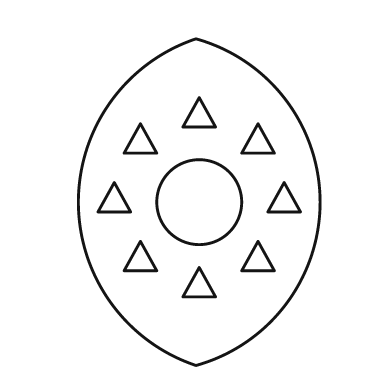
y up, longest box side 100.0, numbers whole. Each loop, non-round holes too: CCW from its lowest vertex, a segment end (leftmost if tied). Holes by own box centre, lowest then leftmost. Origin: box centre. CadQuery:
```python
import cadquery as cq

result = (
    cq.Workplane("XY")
    .moveTo(-1.0, -50.0)
    .threePointArc((37.0, 0.0), (-1.0, 50.0))
    .threePointArc((-37.0, 0.0), (-1.0, -50.0))
    .close()
    .moveTo(-5.0, -29.0)
    .lineTo(5.0, -29.0)
    .lineTo(0.0, -20.0)
    .close()
    .moveTo(-23.0, -21.0)
    .lineTo(-13.0, -21.0)
    .lineTo(-18.0, -12.0)
    .close()
    .moveTo(13.0, -21.0)
    .lineTo(23.0, -21.0)
    .lineTo(18.0, -12.0)
    .close()
    .moveTo(0.0, 0.0)
    .circle(13.0)
    .moveTo(-31.0, -3.0)
    .lineTo(-21.0, -3.0)
    .lineTo(-26.0, 6.0)
    .close()
    .moveTo(21.0, -3.0)
    .lineTo(31.0, -3.0)
    .lineTo(26.0, 6.0)
    .close()
    .moveTo(-23.0, 15.0)
    .lineTo(-13.0, 15.0)
    .lineTo(-18.0, 24.0)
    .close()
    .moveTo(13.0, 15.0)
    .lineTo(23.0, 15.0)
    .lineTo(18.0, 24.0)
    .close()
    .moveTo(-5.0, 23.0)
    .lineTo(5.0, 23.0)
    .lineTo(0.0, 32.0)
    .close()
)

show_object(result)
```